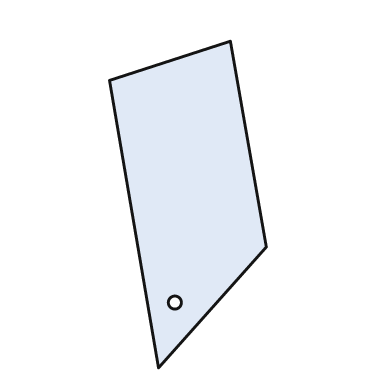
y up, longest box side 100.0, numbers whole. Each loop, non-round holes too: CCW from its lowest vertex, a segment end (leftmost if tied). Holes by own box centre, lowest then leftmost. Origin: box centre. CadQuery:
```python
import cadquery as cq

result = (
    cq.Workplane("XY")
    .moveTo(-9.0, -50.0)
    .lineTo(24.0, -13.0)
    .lineTo(13.0, 50.0)
    .lineTo(-24.0, 38.0)
    .close()
    .moveTo(-4.0, -30.0)
    .circle(2.0)
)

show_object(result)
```